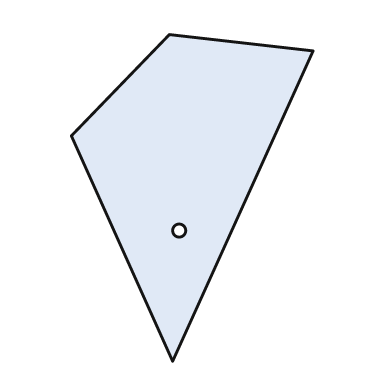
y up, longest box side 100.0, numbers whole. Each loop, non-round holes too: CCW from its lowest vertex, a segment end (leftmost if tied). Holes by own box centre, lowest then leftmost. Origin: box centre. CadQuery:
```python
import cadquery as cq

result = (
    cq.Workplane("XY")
    .moveTo(-6.0, -50.0)
    .lineTo(37.0, 45.0)
    .lineTo(-7.0, 50.0)
    .lineTo(-37.0, 19.0)
    .close()
    .moveTo(-4.0, -10.0)
    .circle(2.0)
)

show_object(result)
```